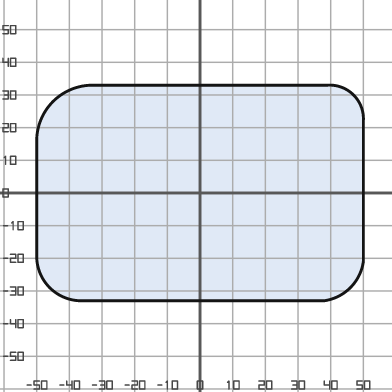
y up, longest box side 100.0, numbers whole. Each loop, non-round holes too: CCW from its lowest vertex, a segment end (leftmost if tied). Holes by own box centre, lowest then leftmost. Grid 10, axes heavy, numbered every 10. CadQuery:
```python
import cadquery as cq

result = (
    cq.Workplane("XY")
    .moveTo(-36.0, -33.0)
    .lineTo(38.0, -33.0)
    .threePointArc((46.0, -29.0), (50.0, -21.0))
    .lineTo(50.0, 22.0)
    .threePointArc((47.0, 30.0), (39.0, 33.0))
    .lineTo(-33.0, 33.0)
    .threePointArc((-45.0, 28.0), (-50.0, 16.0))
    .lineTo(-50.0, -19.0)
    .threePointArc((-46.0, -29.0), (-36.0, -33.0))
    .close()
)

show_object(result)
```